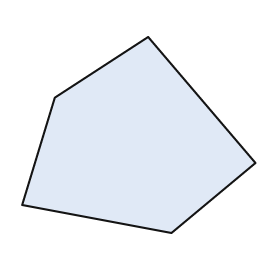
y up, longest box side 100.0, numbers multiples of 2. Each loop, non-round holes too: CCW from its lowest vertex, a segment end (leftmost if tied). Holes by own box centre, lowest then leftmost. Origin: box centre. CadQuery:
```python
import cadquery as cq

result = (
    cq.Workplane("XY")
    .moveTo(14.0, -42.0)
    .lineTo(50.0, -12.0)
    .lineTo(4.0, 42.0)
    .lineTo(-36.0, 16.0)
    .lineTo(-50.0, -30.0)
    .close()
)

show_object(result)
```